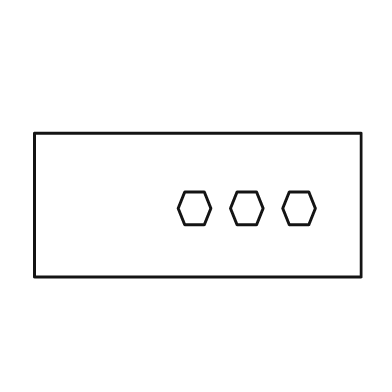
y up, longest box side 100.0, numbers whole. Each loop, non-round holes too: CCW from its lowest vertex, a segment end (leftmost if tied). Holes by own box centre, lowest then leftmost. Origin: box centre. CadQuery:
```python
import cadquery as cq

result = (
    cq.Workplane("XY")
    .moveTo(-50.0, -22.0)
    .lineTo(50.0, -22.0)
    .lineTo(50.0, 22.0)
    .lineTo(-50.0, 22.0)
    .close()
    .moveTo(-4.0, -6.0)
    .lineTo(2.0, -6.0)
    .lineTo(4.0, -1.0)
    .lineTo(2.0, 4.0)
    .lineTo(-4.0, 4.0)
    .lineTo(-6.0, -1.0)
    .close()
    .moveTo(12.0, -6.0)
    .lineTo(18.0, -6.0)
    .lineTo(20.0, -1.0)
    .lineTo(18.0, 4.0)
    .lineTo(12.0, 4.0)
    .lineTo(10.0, -1.0)
    .close()
    .moveTo(28.0, -6.0)
    .lineTo(34.0, -6.0)
    .lineTo(36.0, -1.0)
    .lineTo(34.0, 4.0)
    .lineTo(28.0, 4.0)
    .lineTo(26.0, -1.0)
    .close()
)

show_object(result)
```